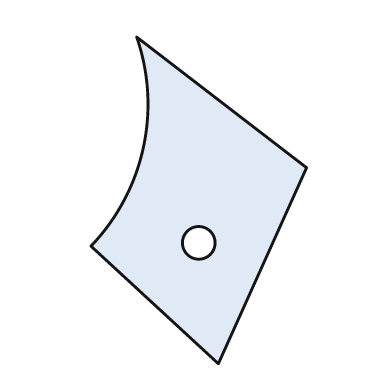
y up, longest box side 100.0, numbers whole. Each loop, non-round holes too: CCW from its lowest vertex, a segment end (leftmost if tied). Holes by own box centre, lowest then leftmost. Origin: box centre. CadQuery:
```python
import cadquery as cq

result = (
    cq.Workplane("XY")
    .moveTo(6.0, -50.0)
    .lineTo(33.0, 10.0)
    .lineTo(-19.0, 50.0)
    .threePointArc((-17.0, 16.0), (-33.0, -14.0))
    .close()
    .moveTo(0.0, -13.0)
    .circle(5.0)
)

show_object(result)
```